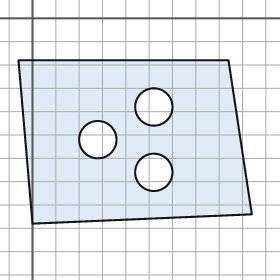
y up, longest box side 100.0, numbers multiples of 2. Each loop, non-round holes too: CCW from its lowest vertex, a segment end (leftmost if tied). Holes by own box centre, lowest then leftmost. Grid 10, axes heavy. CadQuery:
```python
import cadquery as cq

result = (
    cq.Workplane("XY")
    .moveTo(0.0, -88.0)
    .lineTo(94.0, -84.0)
    .lineTo(84.0, -18.0)
    .lineTo(-6.0, -18.0)
    .close()
    .moveTo(52.0, -66.0)
    .circle(8.0)
    .moveTo(28.0, -52.0)
    .circle(8.0)
    .moveTo(52.0, -38.0)
    .circle(8.0)
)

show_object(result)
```